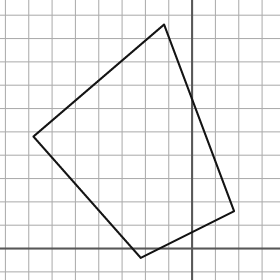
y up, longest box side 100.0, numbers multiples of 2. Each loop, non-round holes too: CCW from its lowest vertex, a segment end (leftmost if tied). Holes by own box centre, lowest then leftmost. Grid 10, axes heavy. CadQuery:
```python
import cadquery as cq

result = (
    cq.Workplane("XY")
    .moveTo(-22.0, -4.0)
    .lineTo(18.0, 16.0)
    .lineTo(-12.0, 96.0)
    .lineTo(-68.0, 48.0)
    .close()
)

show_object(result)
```